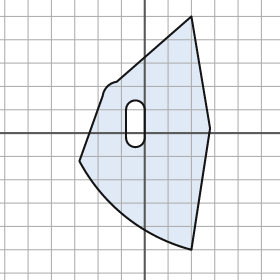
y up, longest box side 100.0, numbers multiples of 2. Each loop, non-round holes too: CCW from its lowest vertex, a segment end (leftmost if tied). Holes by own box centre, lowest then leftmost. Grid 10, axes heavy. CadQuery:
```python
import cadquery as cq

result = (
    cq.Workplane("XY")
    .moveTo(20.0, -50.0)
    .lineTo(28.0, 2.0)
    .lineTo(20.0, 50.0)
    .lineTo(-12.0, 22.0)
    .threePointArc((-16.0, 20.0), (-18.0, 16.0))
    .lineTo(-28.0, -12.0)
    .threePointArc((-8.0, -36.0), (20.0, -50.0))
    .close()
    .moveTo(-8.0, -2.0)
    .threePointArc((-4.0, -6.0), (0.0, -2.0))
    .lineTo(0.0, 10.0)
    .threePointArc((-4.0, 14.0), (-8.0, 10.0))
    .close()
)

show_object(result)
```